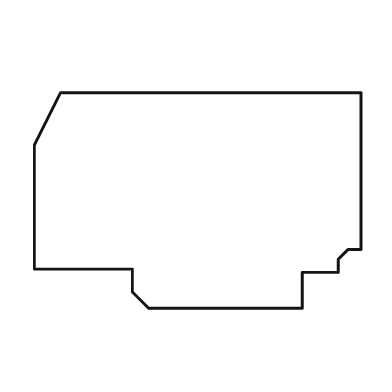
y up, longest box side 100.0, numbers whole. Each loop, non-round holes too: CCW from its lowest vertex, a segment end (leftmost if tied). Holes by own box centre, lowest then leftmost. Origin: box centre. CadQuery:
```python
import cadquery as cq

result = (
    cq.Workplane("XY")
    .moveTo(-15.0, -33.0)
    .lineTo(32.0, -33.0)
    .lineTo(32.0, -22.0)
    .lineTo(43.0, -22.0)
    .lineTo(43.0, -18.0)
    .lineTo(46.0, -15.0)
    .lineTo(50.0, -15.0)
    .lineTo(50.0, 33.0)
    .lineTo(-42.0, 33.0)
    .lineTo(-50.0, 17.0)
    .lineTo(-50.0, -21.0)
    .lineTo(-20.0, -21.0)
    .lineTo(-20.0, -28.0)
    .close()
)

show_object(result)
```